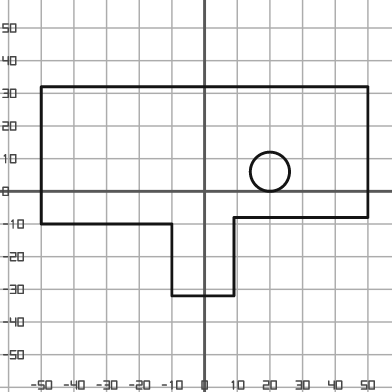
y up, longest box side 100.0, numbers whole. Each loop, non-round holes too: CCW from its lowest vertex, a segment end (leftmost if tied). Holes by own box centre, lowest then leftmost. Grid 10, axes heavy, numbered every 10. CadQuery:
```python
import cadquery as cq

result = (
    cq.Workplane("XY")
    .moveTo(-10.0, -32.0)
    .lineTo(9.0, -32.0)
    .lineTo(9.0, -8.0)
    .lineTo(50.0, -8.0)
    .lineTo(50.0, 32.0)
    .lineTo(-50.0, 32.0)
    .lineTo(-50.0, -10.0)
    .lineTo(-10.0, -10.0)
    .close()
    .moveTo(20.0, 6.0)
    .circle(6.0)
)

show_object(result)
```